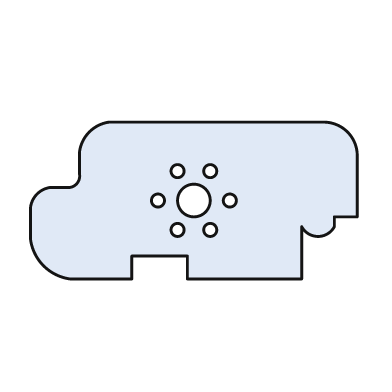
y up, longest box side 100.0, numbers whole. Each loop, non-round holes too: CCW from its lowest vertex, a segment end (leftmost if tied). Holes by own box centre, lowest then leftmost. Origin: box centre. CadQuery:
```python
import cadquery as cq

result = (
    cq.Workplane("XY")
    .moveTo(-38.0, -24.0)
    .lineTo(-19.0, -24.0)
    .lineTo(-19.0, -17.0)
    .lineTo(-2.0, -17.0)
    .lineTo(-2.0, -24.0)
    .lineTo(33.0, -24.0)
    .lineTo(33.0, -8.0)
    .threePointArc((38.0, -11.0), (43.0, -8.0))
    .lineTo(43.0, -5.0)
    .lineTo(50.0, -5.0)
    .lineTo(50.0, 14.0)
    .threePointArc((47.0, 21.0), (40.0, 24.0))
    .lineTo(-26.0, 24.0)
    .threePointArc((-32.0, 21.0), (-35.0, 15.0))
    .lineTo(-35.0, 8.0)
    .threePointArc((-36.0, 5.0), (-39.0, 4.0))
    .lineTo(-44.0, 4.0)
    .threePointArc((-48.0, 2.0), (-50.0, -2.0))
    .lineTo(-50.0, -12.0)
    .threePointArc((-46.0, -20.0), (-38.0, -24.0))
    .close()
    .moveTo(-5.0, -9.0)
    .circle(2.0)
    .moveTo(5.0, -9.0)
    .circle(2.0)
    .moveTo(-11.0, 0.0)
    .circle(2.0)
    .moveTo(0.0, 0.0)
    .circle(5.0)
    .moveTo(11.0, 0.0)
    .circle(2.0)
    .moveTo(-5.0, 9.0)
    .circle(2.0)
    .moveTo(5.0, 9.0)
    .circle(2.0)
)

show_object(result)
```